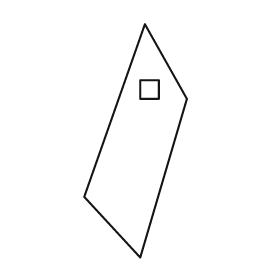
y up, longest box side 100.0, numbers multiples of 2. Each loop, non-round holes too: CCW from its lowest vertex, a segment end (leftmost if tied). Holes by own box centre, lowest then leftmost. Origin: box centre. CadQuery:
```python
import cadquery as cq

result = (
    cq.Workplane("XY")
    .moveTo(2.0, -50.0)
    .lineTo(22.0, 18.0)
    .lineTo(4.0, 50.0)
    .lineTo(-22.0, -24.0)
    .close()
    .moveTo(2.0, 18.0)
    .lineTo(10.0, 18.0)
    .lineTo(10.0, 26.0)
    .lineTo(2.0, 26.0)
    .close()
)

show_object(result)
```